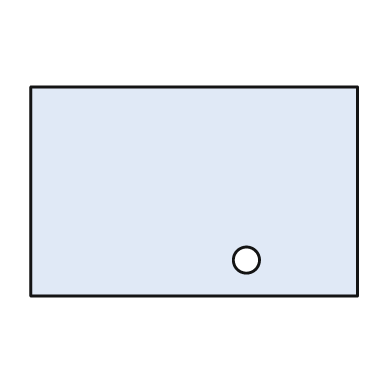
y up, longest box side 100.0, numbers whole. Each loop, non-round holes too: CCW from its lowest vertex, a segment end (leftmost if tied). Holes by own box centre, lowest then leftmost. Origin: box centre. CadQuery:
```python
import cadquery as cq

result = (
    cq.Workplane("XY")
    .moveTo(-50.0, -32.0)
    .lineTo(50.0, -32.0)
    .lineTo(50.0, 32.0)
    .lineTo(-50.0, 32.0)
    .close()
    .moveTo(16.0, -21.0)
    .circle(4.0)
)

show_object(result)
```